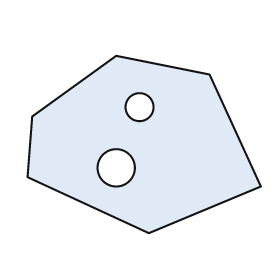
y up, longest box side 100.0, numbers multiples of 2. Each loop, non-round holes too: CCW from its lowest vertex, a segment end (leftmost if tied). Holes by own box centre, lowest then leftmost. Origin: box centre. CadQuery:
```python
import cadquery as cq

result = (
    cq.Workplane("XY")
    .moveTo(2.0, -38.0)
    .lineTo(50.0, -18.0)
    .lineTo(28.0, 30.0)
    .lineTo(-12.0, 38.0)
    .lineTo(-48.0, 12.0)
    .lineTo(-50.0, -14.0)
    .close()
    .moveTo(-12.0, -10.0)
    .circle(8.0)
    .moveTo(-2.0, 16.0)
    .circle(6.0)
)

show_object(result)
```